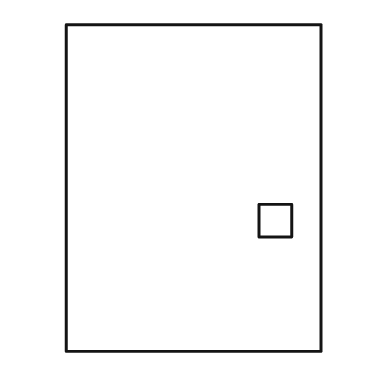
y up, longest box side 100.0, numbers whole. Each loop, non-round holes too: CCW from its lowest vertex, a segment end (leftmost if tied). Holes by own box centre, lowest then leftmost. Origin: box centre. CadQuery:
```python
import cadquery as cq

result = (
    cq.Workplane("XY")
    .moveTo(-39.0, -50.0)
    .lineTo(39.0, -50.0)
    .lineTo(39.0, 50.0)
    .lineTo(-39.0, 50.0)
    .close()
    .moveTo(20.0, -15.0)
    .lineTo(30.0, -15.0)
    .lineTo(30.0, -5.0)
    .lineTo(20.0, -5.0)
    .close()
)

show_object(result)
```